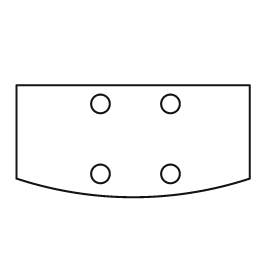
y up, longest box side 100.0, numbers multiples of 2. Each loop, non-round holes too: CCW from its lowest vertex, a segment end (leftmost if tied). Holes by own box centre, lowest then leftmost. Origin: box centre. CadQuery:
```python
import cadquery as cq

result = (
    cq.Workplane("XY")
    .moveTo(-50.0, -16.0)
    .threePointArc((0.0, -24.0), (50.0, -16.0))
    .lineTo(50.0, 24.0)
    .lineTo(-50.0, 24.0)
    .close()
    .moveTo(-14.0, -14.0)
    .circle(4.0)
    .moveTo(16.0, -14.0)
    .circle(4.0)
    .moveTo(-14.0, 16.0)
    .circle(4.0)
    .moveTo(16.0, 16.0)
    .circle(4.0)
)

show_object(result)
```